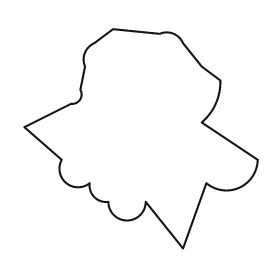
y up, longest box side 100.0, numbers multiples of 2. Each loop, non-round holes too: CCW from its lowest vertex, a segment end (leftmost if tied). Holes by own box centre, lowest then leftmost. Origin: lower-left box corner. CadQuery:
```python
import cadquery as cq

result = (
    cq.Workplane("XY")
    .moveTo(68.0, 0.0)
    .lineTo(78.0, 28.0)
    .threePointArc((92.0, 26.0), (100.0, 38.0))
    .lineTo(76.0, 54.0)
    .threePointArc((82.0, 62.0), (84.0, 72.0))
    .lineTo(76.0, 78.0)
    .lineTo(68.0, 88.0)
    .threePointArc((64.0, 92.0), (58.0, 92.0))
    .lineTo(38.0, 94.0)
    .lineTo(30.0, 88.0)
    .threePointArc((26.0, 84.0), (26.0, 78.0))
    .lineTo(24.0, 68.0)
    .threePointArc((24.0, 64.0), (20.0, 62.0))
    .lineTo(0.0, 52.0)
    .lineTo(16.0, 38.0)
    .threePointArc((18.0, 28.0), (28.0, 28.0))
    .threePointArc((30.0, 22.0), (36.0, 20.0))
    .threePointArc((44.0, 12.0), (52.0, 20.0))
    .close()
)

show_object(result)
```